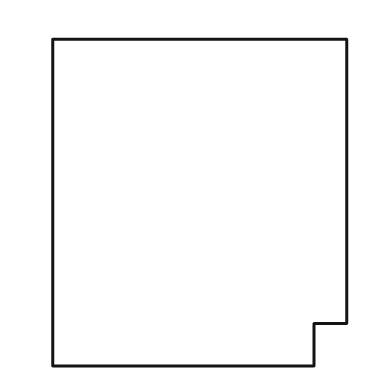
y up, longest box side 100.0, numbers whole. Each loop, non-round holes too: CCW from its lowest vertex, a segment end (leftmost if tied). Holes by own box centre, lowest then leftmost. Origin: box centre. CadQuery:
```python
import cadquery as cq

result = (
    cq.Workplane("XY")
    .moveTo(-45.0, -50.0)
    .lineTo(35.0, -50.0)
    .lineTo(35.0, -37.0)
    .lineTo(45.0, -37.0)
    .lineTo(45.0, 50.0)
    .lineTo(-45.0, 50.0)
    .close()
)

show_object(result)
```